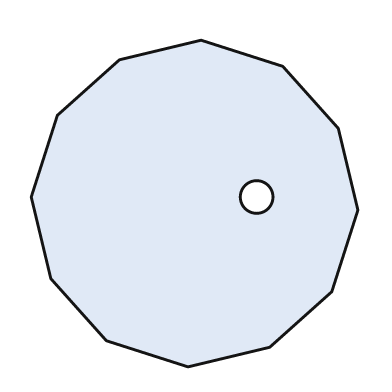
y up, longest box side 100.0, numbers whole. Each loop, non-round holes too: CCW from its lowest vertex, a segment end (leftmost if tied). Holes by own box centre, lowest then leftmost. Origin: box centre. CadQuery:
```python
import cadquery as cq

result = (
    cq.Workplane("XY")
    .moveTo(-2.0, -50.0)
    .lineTo(23.0, -44.0)
    .lineTo(42.0, -27.0)
    .lineTo(50.0, -2.0)
    .lineTo(44.0, 23.0)
    .lineTo(27.0, 42.0)
    .lineTo(2.0, 50.0)
    .lineTo(-23.0, 44.0)
    .lineTo(-42.0, 27.0)
    .lineTo(-50.0, 2.0)
    .lineTo(-44.0, -23.0)
    .lineTo(-27.0, -42.0)
    .close()
    .moveTo(19.0, 2.0)
    .circle(5.0)
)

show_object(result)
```